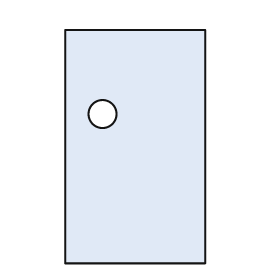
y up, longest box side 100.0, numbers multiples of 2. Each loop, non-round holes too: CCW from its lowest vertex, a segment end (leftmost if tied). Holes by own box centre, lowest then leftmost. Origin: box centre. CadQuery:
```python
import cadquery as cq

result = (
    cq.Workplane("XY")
    .moveTo(-30.0, -50.0)
    .lineTo(30.0, -50.0)
    .lineTo(30.0, 50.0)
    .lineTo(-30.0, 50.0)
    .close()
    .moveTo(-14.0, 14.0)
    .circle(6.0)
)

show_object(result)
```